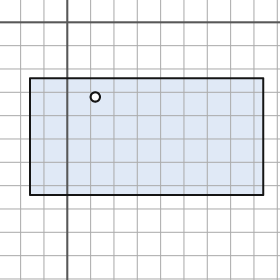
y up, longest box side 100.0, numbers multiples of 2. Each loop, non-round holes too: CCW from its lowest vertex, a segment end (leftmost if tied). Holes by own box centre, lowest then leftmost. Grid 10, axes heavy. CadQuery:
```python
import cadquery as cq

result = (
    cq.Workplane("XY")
    .moveTo(-16.0, -74.0)
    .lineTo(84.0, -74.0)
    .lineTo(84.0, -24.0)
    .lineTo(-16.0, -24.0)
    .close()
    .moveTo(12.0, -32.0)
    .circle(2.0)
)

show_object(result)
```